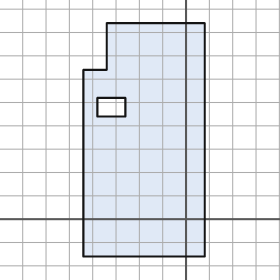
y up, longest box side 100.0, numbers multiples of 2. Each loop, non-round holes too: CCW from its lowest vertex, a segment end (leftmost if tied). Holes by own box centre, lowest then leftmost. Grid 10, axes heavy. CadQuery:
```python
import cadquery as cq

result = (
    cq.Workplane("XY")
    .moveTo(-44.0, -16.0)
    .lineTo(8.0, -16.0)
    .lineTo(8.0, 84.0)
    .lineTo(-34.0, 84.0)
    .lineTo(-34.0, 64.0)
    .lineTo(-44.0, 64.0)
    .close()
    .moveTo(-38.0, 44.0)
    .lineTo(-26.0, 44.0)
    .lineTo(-26.0, 52.0)
    .lineTo(-38.0, 52.0)
    .close()
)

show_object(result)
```